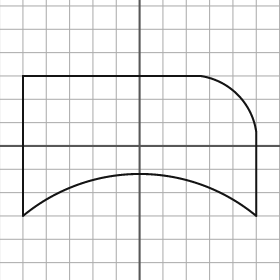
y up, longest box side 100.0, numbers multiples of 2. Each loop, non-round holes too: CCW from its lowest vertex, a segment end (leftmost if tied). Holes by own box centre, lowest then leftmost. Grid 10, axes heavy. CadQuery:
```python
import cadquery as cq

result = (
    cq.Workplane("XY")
    .moveTo(-50.0, -30.0)
    .threePointArc((0.0, -12.0), (50.0, -30.0))
    .lineTo(50.0, 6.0)
    .threePointArc((42.0, 22.0), (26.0, 30.0))
    .lineTo(-50.0, 30.0)
    .close()
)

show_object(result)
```